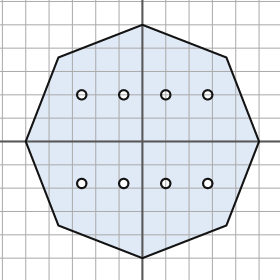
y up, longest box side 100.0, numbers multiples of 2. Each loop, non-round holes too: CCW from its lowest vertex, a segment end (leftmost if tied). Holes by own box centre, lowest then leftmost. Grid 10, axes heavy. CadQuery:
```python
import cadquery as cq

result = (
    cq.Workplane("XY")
    .moveTo(0.0, -50.0)
    .lineTo(36.0, -36.0)
    .lineTo(50.0, 0.0)
    .lineTo(36.0, 36.0)
    .lineTo(0.0, 50.0)
    .lineTo(-36.0, 36.0)
    .lineTo(-50.0, 0.0)
    .lineTo(-36.0, -36.0)
    .close()
    .moveTo(-26.0, -18.0)
    .circle(2.0)
    .moveTo(-8.0, -18.0)
    .circle(2.0)
    .moveTo(10.0, -18.0)
    .circle(2.0)
    .moveTo(28.0, -18.0)
    .circle(2.0)
    .moveTo(-26.0, 20.0)
    .circle(2.0)
    .moveTo(-8.0, 20.0)
    .circle(2.0)
    .moveTo(10.0, 20.0)
    .circle(2.0)
    .moveTo(28.0, 20.0)
    .circle(2.0)
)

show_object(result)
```